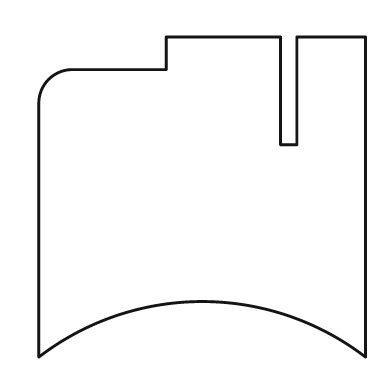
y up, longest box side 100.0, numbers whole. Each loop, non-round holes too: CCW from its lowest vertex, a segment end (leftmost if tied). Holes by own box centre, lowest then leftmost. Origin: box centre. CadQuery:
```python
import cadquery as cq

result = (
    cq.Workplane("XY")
    .moveTo(-50.0, -49.0)
    .threePointArc((0.0, -32.0), (50.0, -49.0))
    .lineTo(50.0, 49.0)
    .lineTo(29.0, 49.0)
    .lineTo(29.0, 16.0)
    .lineTo(24.0, 16.0)
    .lineTo(24.0, 49.0)
    .lineTo(-11.0, 49.0)
    .lineTo(-11.0, 39.0)
    .lineTo(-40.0, 39.0)
    .threePointArc((-47.0, 36.0), (-50.0, 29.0))
    .close()
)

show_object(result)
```